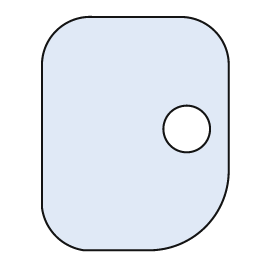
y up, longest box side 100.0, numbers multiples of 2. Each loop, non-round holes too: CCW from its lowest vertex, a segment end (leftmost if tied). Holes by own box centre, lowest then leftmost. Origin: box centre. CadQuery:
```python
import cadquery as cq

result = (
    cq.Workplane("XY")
    .moveTo(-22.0, -50.0)
    .lineTo(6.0, -50.0)
    .threePointArc((30.0, -40.0), (40.0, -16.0))
    .lineTo(40.0, 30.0)
    .threePointArc((34.0, 44.0), (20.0, 50.0))
    .lineTo(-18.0, 50.0)
    .threePointArc((-34.0, 44.0), (-40.0, 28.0))
    .lineTo(-40.0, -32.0)
    .threePointArc((-34.0, -44.0), (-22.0, -50.0))
    .close()
    .moveTo(22.0, 2.0)
    .circle(10.0)
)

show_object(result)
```